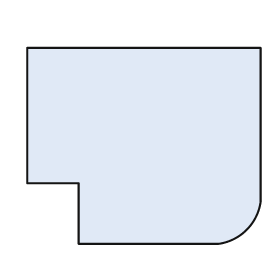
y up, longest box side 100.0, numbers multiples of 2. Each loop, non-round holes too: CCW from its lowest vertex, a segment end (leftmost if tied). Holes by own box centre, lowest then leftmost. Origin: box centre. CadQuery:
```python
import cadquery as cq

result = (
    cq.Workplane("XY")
    .moveTo(-28.0, -42.0)
    .lineTo(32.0, -42.0)
    .threePointArc((44.0, -36.0), (50.0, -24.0))
    .lineTo(50.0, 42.0)
    .lineTo(-50.0, 42.0)
    .lineTo(-50.0, -16.0)
    .lineTo(-28.0, -16.0)
    .close()
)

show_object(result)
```